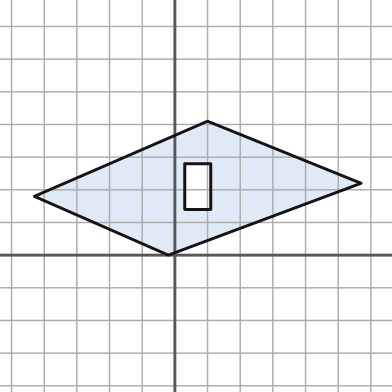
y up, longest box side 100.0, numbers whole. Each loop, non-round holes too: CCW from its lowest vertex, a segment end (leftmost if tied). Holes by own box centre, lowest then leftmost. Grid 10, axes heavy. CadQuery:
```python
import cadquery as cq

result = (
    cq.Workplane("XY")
    .moveTo(-2.0, 0.0)
    .lineTo(57.0, 22.0)
    .lineTo(10.0, 41.0)
    .lineTo(-43.0, 18.0)
    .close()
    .moveTo(3.0, 14.0)
    .lineTo(11.0, 14.0)
    .lineTo(11.0, 28.0)
    .lineTo(3.0, 28.0)
    .close()
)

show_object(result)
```